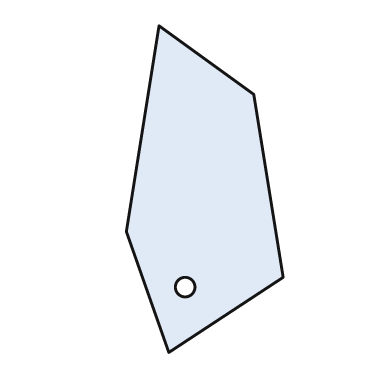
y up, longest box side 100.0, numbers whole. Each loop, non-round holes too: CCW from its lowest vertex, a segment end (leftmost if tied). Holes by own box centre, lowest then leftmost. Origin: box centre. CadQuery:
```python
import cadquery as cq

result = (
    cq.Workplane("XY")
    .moveTo(-11.0, -50.0)
    .lineTo(24.0, -27.0)
    .lineTo(15.0, 29.0)
    .lineTo(-14.0, 50.0)
    .lineTo(-24.0, -13.0)
    .close()
    .moveTo(-6.0, -30.0)
    .circle(3.0)
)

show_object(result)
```